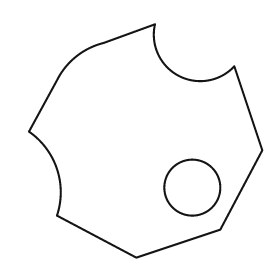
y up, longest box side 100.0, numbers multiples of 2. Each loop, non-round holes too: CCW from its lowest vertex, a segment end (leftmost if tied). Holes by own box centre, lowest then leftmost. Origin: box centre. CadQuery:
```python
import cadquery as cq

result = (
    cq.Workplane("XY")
    .moveTo(-4.0, -50.0)
    .lineTo(32.0, -38.0)
    .lineTo(50.0, -4.0)
    .lineTo(38.0, 32.0)
    .threePointArc((14.0, 28.0), (4.0, 50.0))
    .lineTo(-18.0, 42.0)
    .threePointArc((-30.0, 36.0), (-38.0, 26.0))
    .lineTo(-50.0, 4.0)
    .threePointArc((-38.0, -12.0), (-38.0, -32.0))
    .close()
    .moveTo(20.0, -20.0)
    .circle(12.0)
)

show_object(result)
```